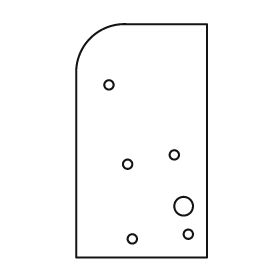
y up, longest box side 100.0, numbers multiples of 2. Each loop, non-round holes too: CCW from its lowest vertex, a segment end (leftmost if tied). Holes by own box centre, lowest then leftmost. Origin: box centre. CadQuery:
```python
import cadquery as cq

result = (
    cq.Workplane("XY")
    .moveTo(-28.0, -50.0)
    .lineTo(28.0, -50.0)
    .lineTo(28.0, 50.0)
    .lineTo(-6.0, 50.0)
    .threePointArc((-22.0, 44.0), (-28.0, 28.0))
    .close()
    .moveTo(-4.0, -42.0)
    .circle(2.0)
    .moveTo(20.0, -40.0)
    .circle(2.0)
    .moveTo(18.0, -28.0)
    .circle(4.0)
    .moveTo(-6.0, -10.0)
    .circle(2.0)
    .moveTo(14.0, -6.0)
    .circle(2.0)
    .moveTo(-14.0, 24.0)
    .circle(2.0)
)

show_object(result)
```